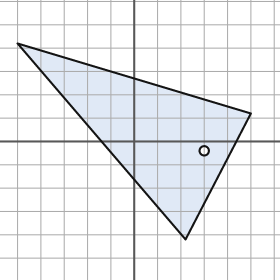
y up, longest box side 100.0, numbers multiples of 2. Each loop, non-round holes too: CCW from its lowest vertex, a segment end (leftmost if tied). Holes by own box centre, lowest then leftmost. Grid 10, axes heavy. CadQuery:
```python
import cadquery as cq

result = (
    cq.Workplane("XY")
    .moveTo(22.0, -42.0)
    .lineTo(50.0, 12.0)
    .lineTo(-50.0, 42.0)
    .close()
    .moveTo(30.0, -4.0)
    .circle(2.0)
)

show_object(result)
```